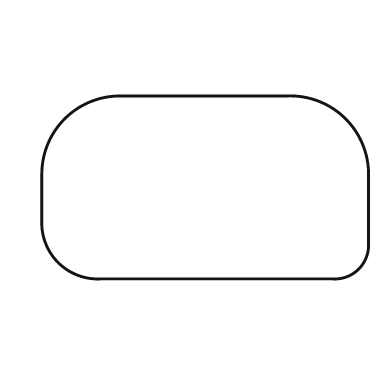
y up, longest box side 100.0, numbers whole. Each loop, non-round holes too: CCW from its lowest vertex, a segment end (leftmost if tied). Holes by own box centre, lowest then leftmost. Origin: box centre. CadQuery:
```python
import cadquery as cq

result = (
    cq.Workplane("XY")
    .moveTo(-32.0, -28.0)
    .lineTo(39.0, -28.0)
    .threePointArc((47.0, -25.0), (50.0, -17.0))
    .lineTo(50.0, 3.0)
    .threePointArc((43.0, 21.0), (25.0, 28.0))
    .lineTo(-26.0, 28.0)
    .threePointArc((-43.0, 21.0), (-50.0, 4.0))
    .lineTo(-50.0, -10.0)
    .threePointArc((-45.0, -23.0), (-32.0, -28.0))
    .close()
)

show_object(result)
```